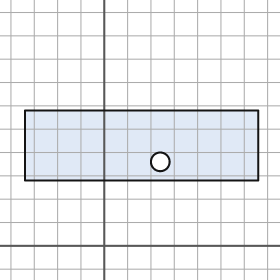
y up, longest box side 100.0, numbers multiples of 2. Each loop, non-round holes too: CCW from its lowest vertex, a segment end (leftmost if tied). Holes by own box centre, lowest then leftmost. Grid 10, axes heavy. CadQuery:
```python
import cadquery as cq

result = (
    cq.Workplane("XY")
    .moveTo(-34.0, 28.0)
    .lineTo(66.0, 28.0)
    .lineTo(66.0, 58.0)
    .lineTo(-34.0, 58.0)
    .close()
    .moveTo(24.0, 36.0)
    .circle(4.0)
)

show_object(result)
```